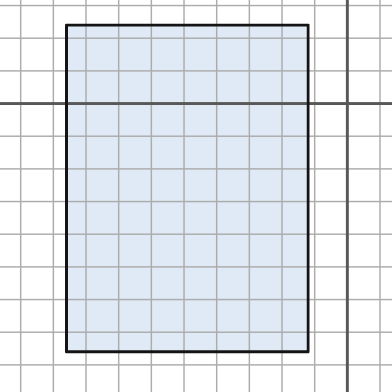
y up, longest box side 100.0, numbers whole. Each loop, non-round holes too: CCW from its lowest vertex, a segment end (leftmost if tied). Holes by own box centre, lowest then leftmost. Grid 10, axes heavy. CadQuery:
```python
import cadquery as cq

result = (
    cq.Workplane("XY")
    .moveTo(-86.0, -76.0)
    .lineTo(-12.0, -76.0)
    .lineTo(-12.0, 24.0)
    .lineTo(-86.0, 24.0)
    .close()
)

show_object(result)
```